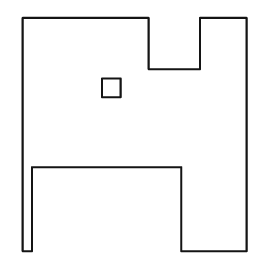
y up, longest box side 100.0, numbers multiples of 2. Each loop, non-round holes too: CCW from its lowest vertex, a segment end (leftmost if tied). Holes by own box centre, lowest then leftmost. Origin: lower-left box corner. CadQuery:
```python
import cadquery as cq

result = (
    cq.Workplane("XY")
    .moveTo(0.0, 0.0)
    .lineTo(4.0, 0.0)
    .lineTo(4.0, 36.0)
    .lineTo(68.0, 36.0)
    .lineTo(68.0, 0.0)
    .lineTo(96.0, 0.0)
    .lineTo(96.0, 100.0)
    .lineTo(76.0, 100.0)
    .lineTo(76.0, 78.0)
    .lineTo(54.0, 78.0)
    .lineTo(54.0, 100.0)
    .lineTo(0.0, 100.0)
    .close()
    .moveTo(34.0, 66.0)
    .lineTo(42.0, 66.0)
    .lineTo(42.0, 74.0)
    .lineTo(34.0, 74.0)
    .close()
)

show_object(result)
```